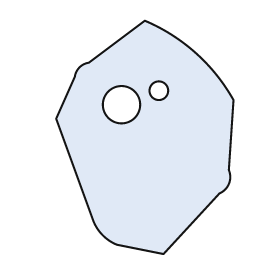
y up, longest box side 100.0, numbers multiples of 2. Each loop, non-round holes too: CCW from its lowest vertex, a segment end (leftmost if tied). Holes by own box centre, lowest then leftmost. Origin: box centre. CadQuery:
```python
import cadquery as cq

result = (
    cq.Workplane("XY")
    .moveTo(8.0, -50.0)
    .lineTo(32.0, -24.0)
    .threePointArc((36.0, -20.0), (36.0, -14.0))
    .lineTo(38.0, 16.0)
    .threePointArc((22.0, 36.0), (0.0, 50.0))
    .lineTo(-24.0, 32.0)
    .threePointArc((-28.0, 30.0), (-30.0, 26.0))
    .lineTo(-38.0, 8.0)
    .lineTo(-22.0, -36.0)
    .threePointArc((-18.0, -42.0), (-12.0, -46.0))
    .close()
    .moveTo(-10.0, 14.0)
    .circle(8.0)
    .moveTo(6.0, 20.0)
    .circle(4.0)
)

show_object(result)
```